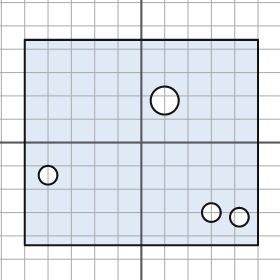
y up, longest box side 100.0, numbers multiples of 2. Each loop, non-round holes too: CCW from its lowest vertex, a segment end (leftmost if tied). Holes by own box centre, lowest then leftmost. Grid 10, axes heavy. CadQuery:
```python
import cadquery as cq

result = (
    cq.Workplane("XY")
    .moveTo(-50.0, -44.0)
    .lineTo(50.0, -44.0)
    .lineTo(50.0, 44.0)
    .lineTo(-50.0, 44.0)
    .close()
    .moveTo(42.0, -32.0)
    .circle(4.0)
    .moveTo(30.0, -30.0)
    .circle(4.0)
    .moveTo(-40.0, -14.0)
    .circle(4.0)
    .moveTo(10.0, 18.0)
    .circle(6.0)
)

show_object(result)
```